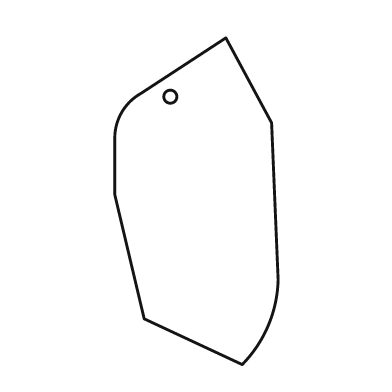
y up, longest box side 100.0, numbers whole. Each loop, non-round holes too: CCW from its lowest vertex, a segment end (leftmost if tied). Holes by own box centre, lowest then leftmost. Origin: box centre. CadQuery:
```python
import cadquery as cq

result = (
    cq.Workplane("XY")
    .moveTo(14.0, -50.0)
    .threePointArc((22.0, -38.0), (25.0, -24.0))
    .lineTo(23.0, 24.0)
    .lineTo(9.0, 50.0)
    .lineTo(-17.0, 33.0)
    .threePointArc((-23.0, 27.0), (-25.0, 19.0))
    .lineTo(-25.0, 2.0)
    .lineTo(-16.0, -36.0)
    .close()
    .moveTo(-8.0, 32.0)
    .circle(2.0)
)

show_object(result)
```